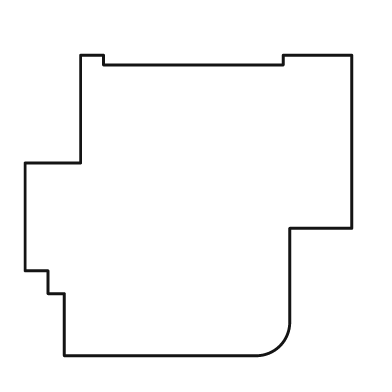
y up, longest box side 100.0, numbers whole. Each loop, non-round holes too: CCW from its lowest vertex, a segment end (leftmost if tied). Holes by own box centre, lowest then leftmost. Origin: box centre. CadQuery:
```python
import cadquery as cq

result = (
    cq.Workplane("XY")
    .moveTo(-38.0, -46.0)
    .lineTo(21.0, -46.0)
    .threePointArc((28.0, -43.0), (31.0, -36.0))
    .lineTo(31.0, -7.0)
    .lineTo(50.0, -7.0)
    .lineTo(50.0, 46.0)
    .lineTo(29.0, 46.0)
    .lineTo(29.0, 43.0)
    .lineTo(-26.0, 43.0)
    .lineTo(-26.0, 46.0)
    .lineTo(-33.0, 46.0)
    .lineTo(-33.0, 13.0)
    .lineTo(-50.0, 13.0)
    .lineTo(-50.0, -20.0)
    .lineTo(-43.0, -20.0)
    .lineTo(-43.0, -27.0)
    .lineTo(-38.0, -27.0)
    .close()
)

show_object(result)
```